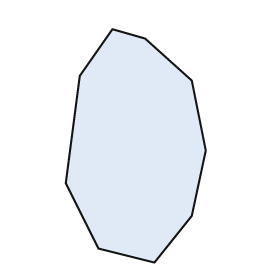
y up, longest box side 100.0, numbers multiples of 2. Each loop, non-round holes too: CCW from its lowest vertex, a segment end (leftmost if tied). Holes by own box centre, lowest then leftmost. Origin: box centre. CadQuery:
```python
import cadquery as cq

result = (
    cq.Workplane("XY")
    .moveTo(8.0, -50.0)
    .lineTo(24.0, -30.0)
    .lineTo(30.0, -2.0)
    .lineTo(24.0, 28.0)
    .lineTo(4.0, 46.0)
    .lineTo(-10.0, 50.0)
    .lineTo(-24.0, 30.0)
    .lineTo(-30.0, -16.0)
    .lineTo(-16.0, -44.0)
    .close()
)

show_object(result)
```